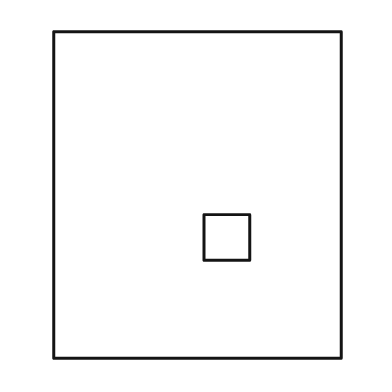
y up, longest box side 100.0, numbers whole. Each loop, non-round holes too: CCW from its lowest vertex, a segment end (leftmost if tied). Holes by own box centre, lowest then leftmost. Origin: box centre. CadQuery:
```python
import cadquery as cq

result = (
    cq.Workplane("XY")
    .moveTo(-44.0, -50.0)
    .lineTo(44.0, -50.0)
    .lineTo(44.0, 50.0)
    .lineTo(-44.0, 50.0)
    .close()
    .moveTo(2.0, -20.0)
    .lineTo(16.0, -20.0)
    .lineTo(16.0, -6.0)
    .lineTo(2.0, -6.0)
    .close()
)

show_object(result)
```